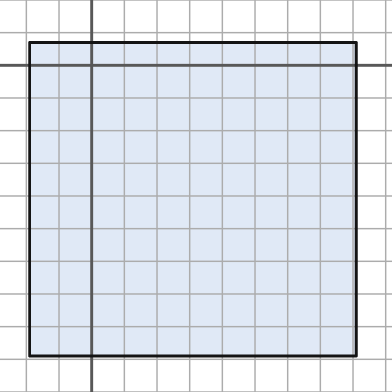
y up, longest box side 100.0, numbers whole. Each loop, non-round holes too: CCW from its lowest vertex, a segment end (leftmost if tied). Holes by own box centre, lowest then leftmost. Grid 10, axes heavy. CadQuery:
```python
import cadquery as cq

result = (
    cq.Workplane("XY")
    .moveTo(-19.0, -89.0)
    .lineTo(81.0, -89.0)
    .lineTo(81.0, 7.0)
    .lineTo(-19.0, 7.0)
    .close()
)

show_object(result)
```